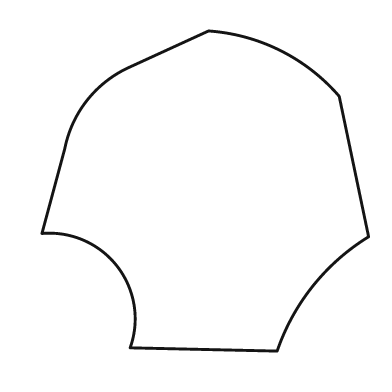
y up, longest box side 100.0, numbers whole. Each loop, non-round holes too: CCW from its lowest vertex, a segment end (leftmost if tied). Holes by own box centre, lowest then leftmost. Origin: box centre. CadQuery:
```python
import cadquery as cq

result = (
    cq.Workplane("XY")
    .moveTo(22.0, -49.0)
    .threePointArc((33.0, -29.0), (50.0, -14.0))
    .lineTo(41.0, 29.0)
    .threePointArc((23.0, 43.0), (1.0, 49.0))
    .lineTo(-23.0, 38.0)
    .threePointArc((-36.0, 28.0), (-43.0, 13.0))
    .lineTo(-50.0, -13.0)
    .threePointArc((-27.0, -23.0), (-23.0, -48.0))
    .close()
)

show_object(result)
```